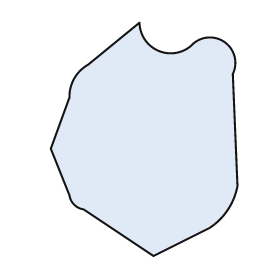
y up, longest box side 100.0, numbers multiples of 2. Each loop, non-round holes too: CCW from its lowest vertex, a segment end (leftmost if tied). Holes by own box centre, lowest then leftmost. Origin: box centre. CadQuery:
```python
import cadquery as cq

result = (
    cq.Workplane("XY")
    .moveTo(4.0, -50.0)
    .lineTo(28.0, -38.0)
    .threePointArc((36.0, -30.0), (40.0, -20.0))
    .lineTo(38.0, 28.0)
    .threePointArc((34.0, 42.0), (20.0, 40.0))
    .threePointArc((6.0, 38.0), (-2.0, 50.0))
    .lineTo(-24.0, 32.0)
    .threePointArc((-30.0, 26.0), (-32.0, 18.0))
    .lineTo(-40.0, -4.0)
    .lineTo(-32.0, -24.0)
    .threePointArc((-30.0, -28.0), (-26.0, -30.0))
    .close()
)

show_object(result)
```